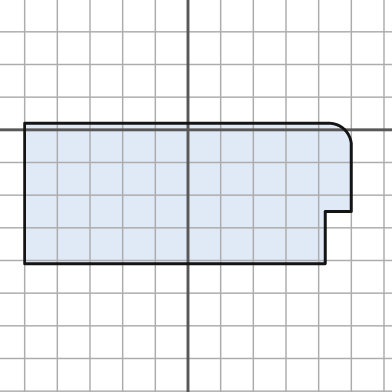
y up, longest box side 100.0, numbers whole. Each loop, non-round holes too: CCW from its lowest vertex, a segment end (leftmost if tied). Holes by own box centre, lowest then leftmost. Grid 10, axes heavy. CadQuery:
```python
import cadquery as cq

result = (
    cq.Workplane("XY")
    .moveTo(-50.0, -41.0)
    .lineTo(42.0, -41.0)
    .lineTo(42.0, -25.0)
    .lineTo(50.0, -25.0)
    .lineTo(50.0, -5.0)
    .threePointArc((48.0, 0.0), (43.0, 2.0))
    .lineTo(-50.0, 2.0)
    .close()
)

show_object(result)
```